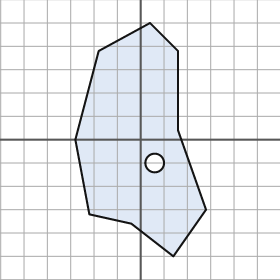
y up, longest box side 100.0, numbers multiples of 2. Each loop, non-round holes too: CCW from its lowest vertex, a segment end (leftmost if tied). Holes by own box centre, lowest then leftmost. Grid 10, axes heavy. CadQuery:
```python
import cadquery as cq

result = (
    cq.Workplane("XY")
    .moveTo(14.0, -50.0)
    .lineTo(28.0, -30.0)
    .lineTo(16.0, 4.0)
    .lineTo(16.0, 38.0)
    .lineTo(4.0, 50.0)
    .lineTo(-18.0, 38.0)
    .lineTo(-28.0, 0.0)
    .lineTo(-22.0, -32.0)
    .lineTo(-4.0, -36.0)
    .close()
    .moveTo(6.0, -10.0)
    .circle(4.0)
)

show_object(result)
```